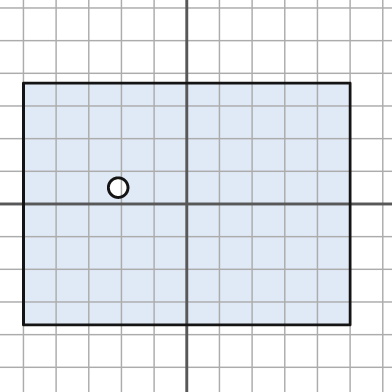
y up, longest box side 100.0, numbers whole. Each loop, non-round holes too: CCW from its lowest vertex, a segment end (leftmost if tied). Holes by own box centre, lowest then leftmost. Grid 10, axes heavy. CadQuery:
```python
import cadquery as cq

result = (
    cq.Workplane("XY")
    .moveTo(-50.0, -37.0)
    .lineTo(50.0, -37.0)
    .lineTo(50.0, 37.0)
    .lineTo(-50.0, 37.0)
    .close()
    .moveTo(-21.0, 5.0)
    .circle(3.0)
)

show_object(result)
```